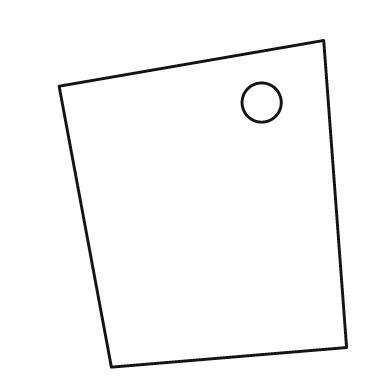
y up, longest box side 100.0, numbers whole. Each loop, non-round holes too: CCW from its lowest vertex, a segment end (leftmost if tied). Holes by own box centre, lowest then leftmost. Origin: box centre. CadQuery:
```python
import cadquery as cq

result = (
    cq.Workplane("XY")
    .moveTo(-28.0, -50.0)
    .lineTo(44.0, -44.0)
    .lineTo(37.0, 50.0)
    .lineTo(-44.0, 36.0)
    .close()
    .moveTo(18.0, 31.0)
    .circle(6.0)
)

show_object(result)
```